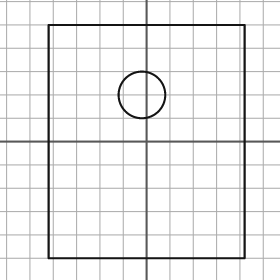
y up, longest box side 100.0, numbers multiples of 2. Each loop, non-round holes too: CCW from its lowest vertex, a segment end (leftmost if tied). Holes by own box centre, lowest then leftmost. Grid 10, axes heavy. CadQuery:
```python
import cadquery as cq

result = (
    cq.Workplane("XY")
    .moveTo(-42.0, -50.0)
    .lineTo(42.0, -50.0)
    .lineTo(42.0, 50.0)
    .lineTo(-42.0, 50.0)
    .close()
    .moveTo(-2.0, 20.0)
    .circle(10.0)
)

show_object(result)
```